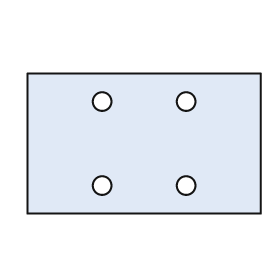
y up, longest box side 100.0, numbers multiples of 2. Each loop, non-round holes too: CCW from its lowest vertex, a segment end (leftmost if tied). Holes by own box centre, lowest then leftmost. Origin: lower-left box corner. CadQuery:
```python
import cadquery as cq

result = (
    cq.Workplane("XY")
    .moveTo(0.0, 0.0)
    .lineTo(100.0, 0.0)
    .lineTo(100.0, 60.0)
    .lineTo(0.0, 60.0)
    .close()
    .moveTo(32.0, 12.0)
    .circle(4.0)
    .moveTo(68.0, 12.0)
    .circle(4.0)
    .moveTo(32.0, 48.0)
    .circle(4.0)
    .moveTo(68.0, 48.0)
    .circle(4.0)
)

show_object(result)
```